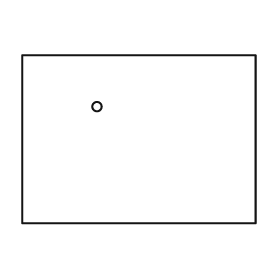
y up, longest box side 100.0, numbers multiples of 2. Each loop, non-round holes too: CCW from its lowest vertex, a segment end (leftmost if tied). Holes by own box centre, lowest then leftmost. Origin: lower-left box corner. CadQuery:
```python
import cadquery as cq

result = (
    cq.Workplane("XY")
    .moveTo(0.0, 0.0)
    .lineTo(100.0, 0.0)
    .lineTo(100.0, 72.0)
    .lineTo(0.0, 72.0)
    .close()
    .moveTo(32.0, 50.0)
    .circle(2.0)
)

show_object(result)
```